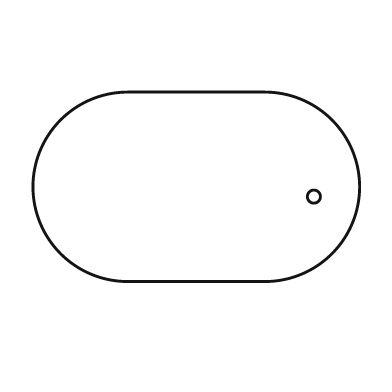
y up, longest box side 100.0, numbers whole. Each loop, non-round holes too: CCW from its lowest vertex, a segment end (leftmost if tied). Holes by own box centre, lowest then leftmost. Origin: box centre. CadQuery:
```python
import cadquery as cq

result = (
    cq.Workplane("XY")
    .moveTo(-21.0, -29.0)
    .lineTo(21.0, -29.0)
    .threePointArc((50.0, 0.0), (21.0, 29.0))
    .lineTo(-21.0, 29.0)
    .threePointArc((-50.0, 0.0), (-21.0, -29.0))
    .close()
    .moveTo(36.0, -3.0)
    .circle(2.0)
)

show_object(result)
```